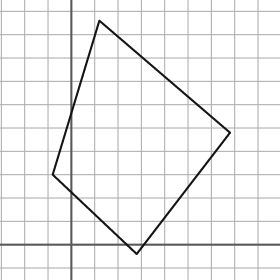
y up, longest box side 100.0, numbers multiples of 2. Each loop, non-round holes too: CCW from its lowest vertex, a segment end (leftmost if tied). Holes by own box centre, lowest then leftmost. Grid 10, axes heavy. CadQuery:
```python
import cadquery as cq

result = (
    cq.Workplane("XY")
    .moveTo(28.0, -4.0)
    .lineTo(68.0, 48.0)
    .lineTo(12.0, 96.0)
    .lineTo(-8.0, 30.0)
    .close()
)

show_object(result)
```